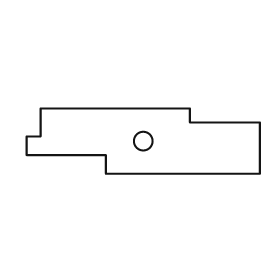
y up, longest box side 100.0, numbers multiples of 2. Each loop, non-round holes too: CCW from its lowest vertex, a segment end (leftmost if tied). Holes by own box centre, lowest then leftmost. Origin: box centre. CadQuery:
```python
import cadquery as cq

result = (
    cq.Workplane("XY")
    .moveTo(-16.0, -14.0)
    .lineTo(50.0, -14.0)
    .lineTo(50.0, 8.0)
    .lineTo(20.0, 8.0)
    .lineTo(20.0, 14.0)
    .lineTo(-44.0, 14.0)
    .lineTo(-44.0, 2.0)
    .lineTo(-50.0, 2.0)
    .lineTo(-50.0, -6.0)
    .lineTo(-16.0, -6.0)
    .close()
    .moveTo(0.0, 0.0)
    .circle(4.0)
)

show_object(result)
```